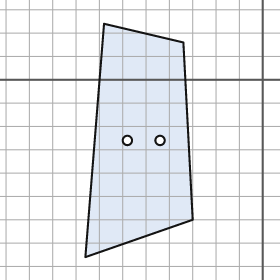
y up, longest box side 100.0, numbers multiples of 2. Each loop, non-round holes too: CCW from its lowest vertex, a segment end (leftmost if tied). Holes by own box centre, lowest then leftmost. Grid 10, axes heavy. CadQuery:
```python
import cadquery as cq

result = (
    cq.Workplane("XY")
    .moveTo(-76.0, -76.0)
    .lineTo(-30.0, -60.0)
    .lineTo(-34.0, 16.0)
    .lineTo(-68.0, 24.0)
    .close()
    .moveTo(-58.0, -26.0)
    .circle(2.0)
    .moveTo(-44.0, -26.0)
    .circle(2.0)
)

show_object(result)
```